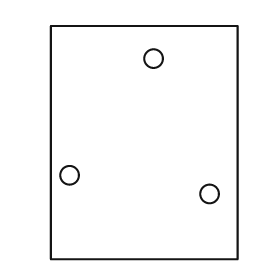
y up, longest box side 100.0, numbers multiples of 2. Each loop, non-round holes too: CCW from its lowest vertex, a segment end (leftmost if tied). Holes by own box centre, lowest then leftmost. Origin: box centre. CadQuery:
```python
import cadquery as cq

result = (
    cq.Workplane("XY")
    .moveTo(-40.0, -50.0)
    .lineTo(40.0, -50.0)
    .lineTo(40.0, 50.0)
    .lineTo(-40.0, 50.0)
    .close()
    .moveTo(28.0, -22.0)
    .circle(4.0)
    .moveTo(-32.0, -14.0)
    .circle(4.0)
    .moveTo(4.0, 36.0)
    .circle(4.0)
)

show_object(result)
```